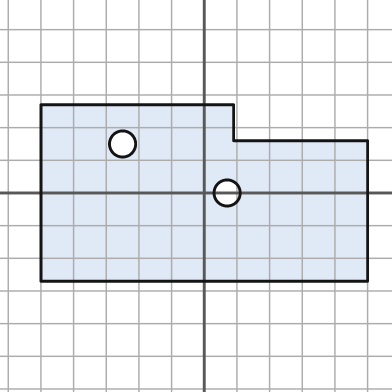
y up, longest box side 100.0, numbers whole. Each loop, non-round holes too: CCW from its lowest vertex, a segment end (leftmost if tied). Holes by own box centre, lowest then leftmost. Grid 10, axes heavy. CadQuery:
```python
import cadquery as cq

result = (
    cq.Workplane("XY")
    .moveTo(-50.0, -27.0)
    .lineTo(50.0, -27.0)
    .lineTo(50.0, 16.0)
    .lineTo(9.0, 16.0)
    .lineTo(9.0, 27.0)
    .lineTo(-50.0, 27.0)
    .close()
    .moveTo(7.0, 0.0)
    .circle(4.0)
    .moveTo(-25.0, 15.0)
    .circle(4.0)
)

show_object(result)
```